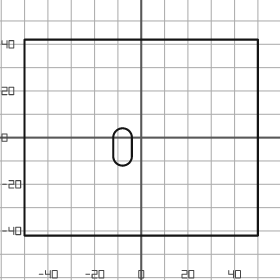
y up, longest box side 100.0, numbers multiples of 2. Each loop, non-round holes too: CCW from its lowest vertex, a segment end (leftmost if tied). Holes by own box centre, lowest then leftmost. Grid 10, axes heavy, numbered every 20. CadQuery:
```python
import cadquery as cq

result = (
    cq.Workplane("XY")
    .moveTo(-50.0, -42.0)
    .lineTo(50.0, -42.0)
    .lineTo(50.0, 42.0)
    .lineTo(-50.0, 42.0)
    .close()
    .moveTo(-12.0, -8.0)
    .threePointArc((-8.0, -12.0), (-4.0, -8.0))
    .lineTo(-4.0, 0.0)
    .threePointArc((-8.0, 4.0), (-12.0, 0.0))
    .close()
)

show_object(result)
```